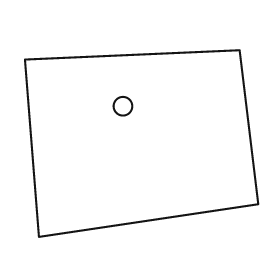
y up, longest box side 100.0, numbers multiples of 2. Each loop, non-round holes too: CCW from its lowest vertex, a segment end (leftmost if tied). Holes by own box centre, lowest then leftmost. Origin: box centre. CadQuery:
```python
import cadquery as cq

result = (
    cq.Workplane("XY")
    .moveTo(-44.0, -40.0)
    .lineTo(50.0, -26.0)
    .lineTo(42.0, 40.0)
    .lineTo(-50.0, 36.0)
    .close()
    .moveTo(-8.0, 16.0)
    .circle(4.0)
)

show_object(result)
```